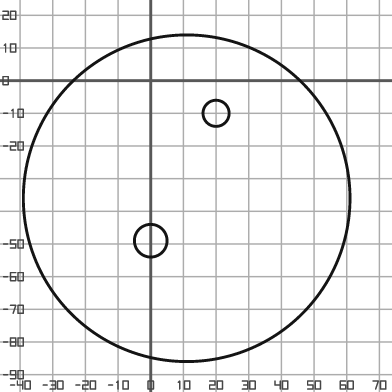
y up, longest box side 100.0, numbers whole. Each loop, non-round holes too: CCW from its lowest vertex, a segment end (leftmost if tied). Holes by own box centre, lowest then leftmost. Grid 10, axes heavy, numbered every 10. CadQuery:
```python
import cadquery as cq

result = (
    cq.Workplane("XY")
    .moveTo(11.0, -36.0)
    .circle(50.0)
    .moveTo(0.0, -49.0)
    .circle(5.0)
    .moveTo(20.0, -10.0)
    .circle(4.0)
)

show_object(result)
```